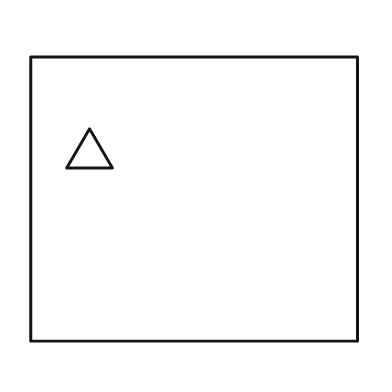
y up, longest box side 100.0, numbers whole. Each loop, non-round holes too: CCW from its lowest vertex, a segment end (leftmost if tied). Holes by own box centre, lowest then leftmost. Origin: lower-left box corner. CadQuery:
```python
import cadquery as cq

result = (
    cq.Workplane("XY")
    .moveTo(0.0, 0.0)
    .lineTo(100.0, 0.0)
    .lineTo(100.0, 87.0)
    .lineTo(0.0, 87.0)
    .close()
    .moveTo(11.0, 53.0)
    .lineTo(25.0, 53.0)
    .lineTo(18.0, 65.0)
    .close()
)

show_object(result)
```